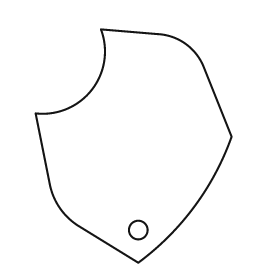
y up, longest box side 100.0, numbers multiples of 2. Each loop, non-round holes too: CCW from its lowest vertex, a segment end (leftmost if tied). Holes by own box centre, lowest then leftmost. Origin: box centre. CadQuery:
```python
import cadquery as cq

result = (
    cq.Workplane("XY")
    .moveTo(2.0, -50.0)
    .threePointArc((26.0, -26.0), (42.0, 4.0))
    .lineTo(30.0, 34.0)
    .threePointArc((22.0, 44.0), (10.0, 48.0))
    .lineTo(-14.0, 50.0)
    .threePointArc((-18.0, 24.0), (-42.0, 14.0))
    .lineTo(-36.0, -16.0)
    .threePointArc((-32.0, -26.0), (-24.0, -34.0))
    .close()
    .moveTo(2.0, -36.0)
    .circle(4.0)
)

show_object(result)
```